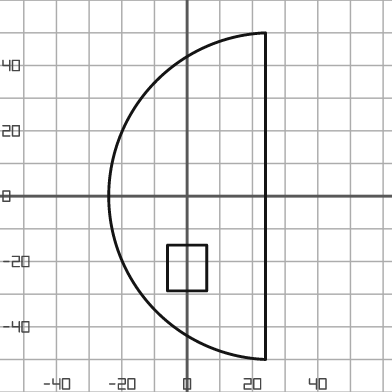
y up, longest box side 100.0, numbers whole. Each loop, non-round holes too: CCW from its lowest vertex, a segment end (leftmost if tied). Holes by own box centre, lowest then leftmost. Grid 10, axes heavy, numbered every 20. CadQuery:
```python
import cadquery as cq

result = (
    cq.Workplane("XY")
    .moveTo(24.0, -50.0)
    .lineTo(24.0, 50.0)
    .threePointArc((-24.0, 0.0), (24.0, -50.0))
    .close()
    .moveTo(-6.0, -29.0)
    .lineTo(6.0, -29.0)
    .lineTo(6.0, -15.0)
    .lineTo(-6.0, -15.0)
    .close()
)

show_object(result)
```